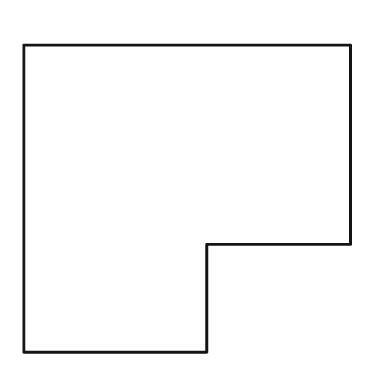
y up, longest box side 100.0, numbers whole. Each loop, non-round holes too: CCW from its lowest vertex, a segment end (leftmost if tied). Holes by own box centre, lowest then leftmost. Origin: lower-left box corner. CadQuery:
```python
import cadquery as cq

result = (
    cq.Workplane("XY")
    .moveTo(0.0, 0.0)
    .lineTo(56.0, 0.0)
    .lineTo(56.0, 33.0)
    .lineTo(100.0, 33.0)
    .lineTo(100.0, 94.0)
    .lineTo(0.0, 94.0)
    .close()
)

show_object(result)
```